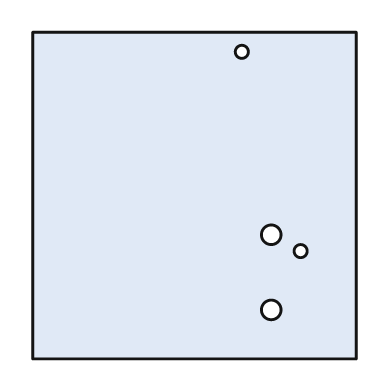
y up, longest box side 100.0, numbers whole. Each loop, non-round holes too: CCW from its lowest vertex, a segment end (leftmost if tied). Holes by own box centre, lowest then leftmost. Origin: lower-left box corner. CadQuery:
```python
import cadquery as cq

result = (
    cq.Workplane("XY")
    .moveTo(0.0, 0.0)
    .lineTo(99.0, 0.0)
    .lineTo(99.0, 100.0)
    .lineTo(0.0, 100.0)
    .close()
    .moveTo(73.0, 15.0)
    .circle(3.0)
    .moveTo(82.0, 33.0)
    .circle(2.0)
    .moveTo(73.0, 38.0)
    .circle(3.0)
    .moveTo(64.0, 94.0)
    .circle(2.0)
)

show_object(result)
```